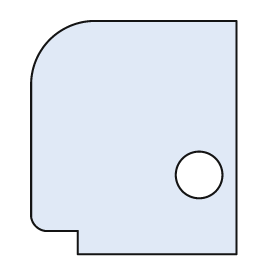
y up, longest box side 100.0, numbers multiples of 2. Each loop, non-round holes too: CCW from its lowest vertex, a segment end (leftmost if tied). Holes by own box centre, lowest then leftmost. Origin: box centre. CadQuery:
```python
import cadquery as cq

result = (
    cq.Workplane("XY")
    .moveTo(-24.0, -50.0)
    .lineTo(44.0, -50.0)
    .lineTo(44.0, 50.0)
    .lineTo(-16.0, 50.0)
    .threePointArc((-36.0, 42.0), (-44.0, 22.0))
    .lineTo(-44.0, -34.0)
    .threePointArc((-42.0, -38.0), (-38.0, -40.0))
    .lineTo(-24.0, -40.0)
    .close()
    .moveTo(28.0, -16.0)
    .circle(10.0)
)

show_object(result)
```